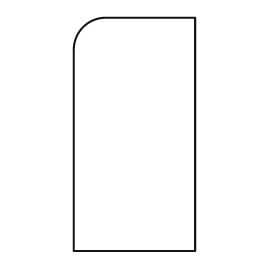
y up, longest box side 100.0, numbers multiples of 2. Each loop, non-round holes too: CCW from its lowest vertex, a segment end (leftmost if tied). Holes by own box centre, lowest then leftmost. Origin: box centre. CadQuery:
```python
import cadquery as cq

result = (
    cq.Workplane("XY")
    .moveTo(-26.0, -50.0)
    .lineTo(26.0, -50.0)
    .lineTo(26.0, 50.0)
    .lineTo(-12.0, 50.0)
    .threePointArc((-22.0, 46.0), (-26.0, 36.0))
    .close()
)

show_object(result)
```